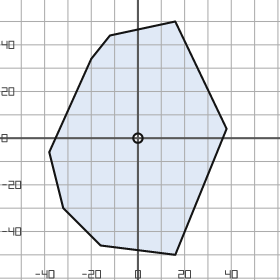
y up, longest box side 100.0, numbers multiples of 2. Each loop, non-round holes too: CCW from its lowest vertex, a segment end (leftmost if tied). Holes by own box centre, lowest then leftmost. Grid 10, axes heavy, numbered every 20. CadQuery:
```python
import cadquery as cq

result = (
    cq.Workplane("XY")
    .moveTo(16.0, -50.0)
    .lineTo(38.0, 4.0)
    .lineTo(16.0, 50.0)
    .lineTo(-12.0, 44.0)
    .lineTo(-20.0, 34.0)
    .lineTo(-38.0, -6.0)
    .lineTo(-32.0, -30.0)
    .lineTo(-16.0, -46.0)
    .close()
    .moveTo(0.0, 0.0)
    .circle(2.0)
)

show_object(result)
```